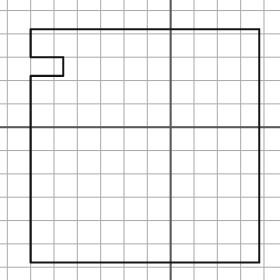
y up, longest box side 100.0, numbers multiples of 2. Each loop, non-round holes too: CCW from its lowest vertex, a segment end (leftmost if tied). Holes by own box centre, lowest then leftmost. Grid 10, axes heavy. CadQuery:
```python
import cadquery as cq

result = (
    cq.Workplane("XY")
    .moveTo(-60.0, -58.0)
    .lineTo(38.0, -58.0)
    .lineTo(38.0, 42.0)
    .lineTo(-60.0, 42.0)
    .lineTo(-60.0, 30.0)
    .lineTo(-46.0, 30.0)
    .lineTo(-46.0, 22.0)
    .lineTo(-60.0, 22.0)
    .close()
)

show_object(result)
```